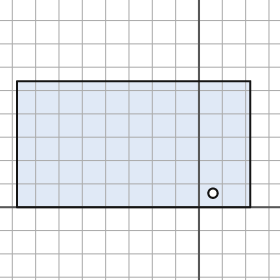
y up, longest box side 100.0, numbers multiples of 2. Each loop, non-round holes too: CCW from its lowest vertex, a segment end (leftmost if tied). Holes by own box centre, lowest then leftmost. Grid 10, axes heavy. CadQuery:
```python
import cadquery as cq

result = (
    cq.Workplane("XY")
    .moveTo(-78.0, 0.0)
    .lineTo(22.0, 0.0)
    .lineTo(22.0, 54.0)
    .lineTo(-78.0, 54.0)
    .close()
    .moveTo(6.0, 6.0)
    .circle(2.0)
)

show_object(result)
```